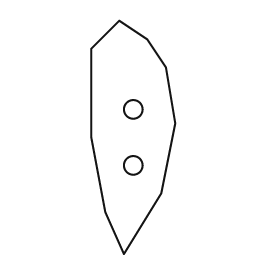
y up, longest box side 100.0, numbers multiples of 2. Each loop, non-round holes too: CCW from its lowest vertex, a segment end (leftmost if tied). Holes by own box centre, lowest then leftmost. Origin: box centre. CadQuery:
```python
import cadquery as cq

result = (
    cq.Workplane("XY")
    .moveTo(-4.0, -50.0)
    .lineTo(12.0, -24.0)
    .lineTo(18.0, 6.0)
    .lineTo(14.0, 30.0)
    .lineTo(6.0, 42.0)
    .lineTo(-6.0, 50.0)
    .lineTo(-18.0, 38.0)
    .lineTo(-18.0, 0.0)
    .lineTo(-12.0, -32.0)
    .close()
    .moveTo(0.0, -12.0)
    .circle(4.0)
    .moveTo(0.0, 12.0)
    .circle(4.0)
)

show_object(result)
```